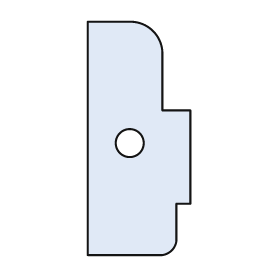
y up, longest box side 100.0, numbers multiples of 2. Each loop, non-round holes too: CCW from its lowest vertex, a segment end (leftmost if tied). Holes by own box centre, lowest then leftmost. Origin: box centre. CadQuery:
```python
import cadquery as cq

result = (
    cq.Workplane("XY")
    .moveTo(-22.0, -50.0)
    .lineTo(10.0, -50.0)
    .threePointArc((14.0, -48.0), (16.0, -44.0))
    .lineTo(16.0, -28.0)
    .lineTo(22.0, -28.0)
    .lineTo(22.0, 12.0)
    .lineTo(10.0, 12.0)
    .lineTo(10.0, 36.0)
    .threePointArc((6.0, 46.0), (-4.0, 50.0))
    .lineTo(-22.0, 50.0)
    .close()
    .moveTo(-4.0, -2.0)
    .circle(6.0)
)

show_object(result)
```